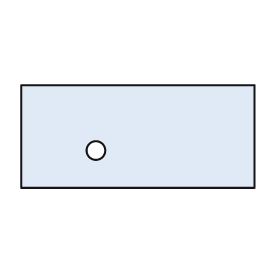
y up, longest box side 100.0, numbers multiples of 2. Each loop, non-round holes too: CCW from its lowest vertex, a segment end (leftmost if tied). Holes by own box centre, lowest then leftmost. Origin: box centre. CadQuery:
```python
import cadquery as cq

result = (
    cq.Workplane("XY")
    .moveTo(-50.0, -22.0)
    .lineTo(50.0, -22.0)
    .lineTo(50.0, 22.0)
    .lineTo(-50.0, 22.0)
    .close()
    .moveTo(-18.0, -6.0)
    .circle(4.0)
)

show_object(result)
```